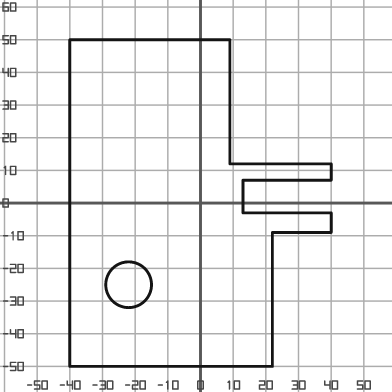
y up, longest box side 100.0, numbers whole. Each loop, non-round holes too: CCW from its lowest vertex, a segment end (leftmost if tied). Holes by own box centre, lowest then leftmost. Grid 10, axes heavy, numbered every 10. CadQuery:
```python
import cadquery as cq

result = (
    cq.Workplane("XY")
    .moveTo(-40.0, -50.0)
    .lineTo(22.0, -50.0)
    .lineTo(22.0, -9.0)
    .lineTo(40.0, -9.0)
    .lineTo(40.0, -3.0)
    .lineTo(13.0, -3.0)
    .lineTo(13.0, 7.0)
    .lineTo(40.0, 7.0)
    .lineTo(40.0, 12.0)
    .lineTo(9.0, 12.0)
    .lineTo(9.0, 50.0)
    .lineTo(-40.0, 50.0)
    .close()
    .moveTo(-22.0, -25.0)
    .circle(7.0)
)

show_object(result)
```